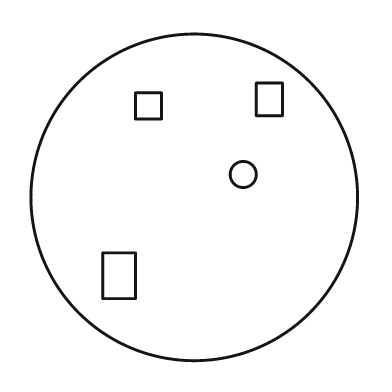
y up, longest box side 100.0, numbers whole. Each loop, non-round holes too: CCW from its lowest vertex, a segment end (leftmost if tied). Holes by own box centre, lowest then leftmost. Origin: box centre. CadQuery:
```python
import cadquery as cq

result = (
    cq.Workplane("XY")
    .moveTo(0.0, 0.0)
    .circle(50.0)
    .moveTo(-28.0, -31.0)
    .lineTo(-18.0, -31.0)
    .lineTo(-18.0, -17.0)
    .lineTo(-28.0, -17.0)
    .close()
    .moveTo(15.0, 7.0)
    .circle(4.0)
    .moveTo(-18.0, 24.0)
    .lineTo(-10.0, 24.0)
    .lineTo(-10.0, 32.0)
    .lineTo(-18.0, 32.0)
    .close()
    .moveTo(19.0, 25.0)
    .lineTo(27.0, 25.0)
    .lineTo(27.0, 35.0)
    .lineTo(19.0, 35.0)
    .close()
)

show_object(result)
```